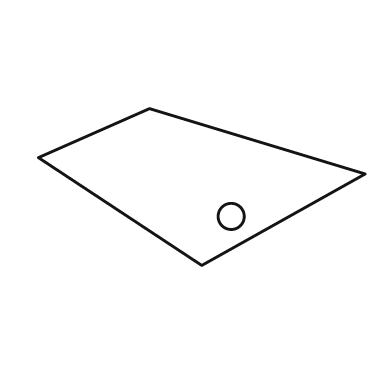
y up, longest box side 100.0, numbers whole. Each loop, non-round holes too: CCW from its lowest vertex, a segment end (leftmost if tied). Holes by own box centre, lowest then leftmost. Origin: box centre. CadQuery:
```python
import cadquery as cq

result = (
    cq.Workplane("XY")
    .moveTo(0.0, -24.0)
    .lineTo(50.0, 4.0)
    .lineTo(-16.0, 24.0)
    .lineTo(-50.0, 9.0)
    .close()
    .moveTo(9.0, -9.0)
    .circle(4.0)
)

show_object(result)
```